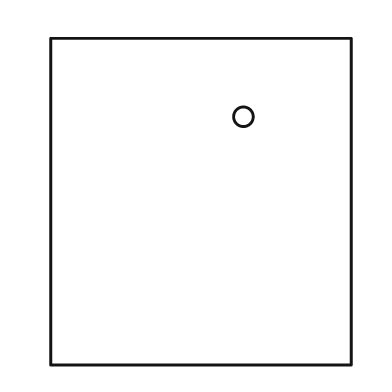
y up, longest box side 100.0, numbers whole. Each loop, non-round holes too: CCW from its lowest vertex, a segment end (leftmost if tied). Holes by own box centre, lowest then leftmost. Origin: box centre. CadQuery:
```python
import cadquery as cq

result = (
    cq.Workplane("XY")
    .moveTo(-46.0, -50.0)
    .lineTo(46.0, -50.0)
    .lineTo(46.0, 50.0)
    .lineTo(-46.0, 50.0)
    .close()
    .moveTo(13.0, 26.0)
    .circle(3.0)
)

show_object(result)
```